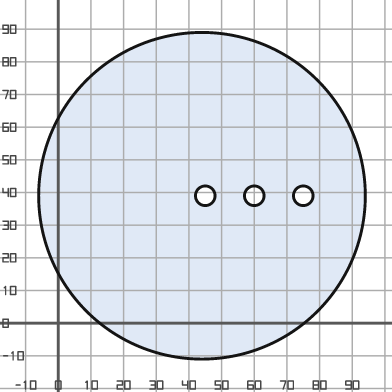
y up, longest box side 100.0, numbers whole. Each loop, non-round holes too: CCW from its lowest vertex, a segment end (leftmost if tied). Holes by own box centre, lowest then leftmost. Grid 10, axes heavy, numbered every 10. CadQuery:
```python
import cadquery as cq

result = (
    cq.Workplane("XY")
    .moveTo(44.0, 39.0)
    .circle(50.0)
    .moveTo(45.0, 39.0)
    .circle(3.0)
    .moveTo(60.0, 39.0)
    .circle(3.0)
    .moveTo(75.0, 39.0)
    .circle(3.0)
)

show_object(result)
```